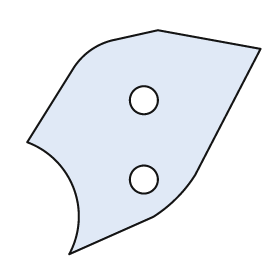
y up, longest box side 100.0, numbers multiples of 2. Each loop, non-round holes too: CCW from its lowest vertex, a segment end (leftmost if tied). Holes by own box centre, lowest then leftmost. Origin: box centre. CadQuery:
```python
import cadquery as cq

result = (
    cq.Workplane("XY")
    .moveTo(-32.0, -48.0)
    .lineTo(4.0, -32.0)
    .threePointArc((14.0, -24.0), (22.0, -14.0))
    .lineTo(50.0, 40.0)
    .lineTo(6.0, 48.0)
    .lineTo(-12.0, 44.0)
    .threePointArc((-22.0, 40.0), (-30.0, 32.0))
    .lineTo(-50.0, 0.0)
    .threePointArc((-30.0, -20.0), (-32.0, -48.0))
    .close()
    .moveTo(0.0, -16.0)
    .circle(6.0)
    .moveTo(0.0, 18.0)
    .circle(6.0)
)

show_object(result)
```